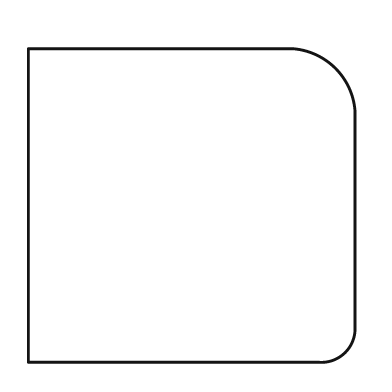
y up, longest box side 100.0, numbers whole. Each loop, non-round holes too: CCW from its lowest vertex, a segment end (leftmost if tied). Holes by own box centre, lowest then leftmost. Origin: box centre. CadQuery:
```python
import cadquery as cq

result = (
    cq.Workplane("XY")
    .moveTo(-50.0, -48.0)
    .lineTo(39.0, -48.0)
    .threePointArc((47.0, -45.0), (50.0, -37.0))
    .lineTo(50.0, 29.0)
    .threePointArc((44.0, 42.0), (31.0, 48.0))
    .lineTo(-50.0, 48.0)
    .close()
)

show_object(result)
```